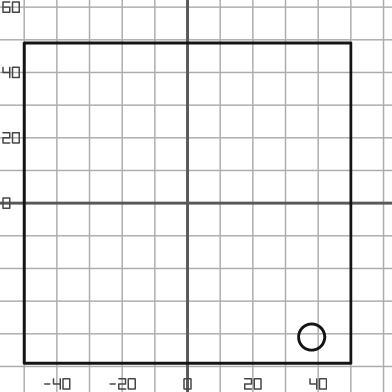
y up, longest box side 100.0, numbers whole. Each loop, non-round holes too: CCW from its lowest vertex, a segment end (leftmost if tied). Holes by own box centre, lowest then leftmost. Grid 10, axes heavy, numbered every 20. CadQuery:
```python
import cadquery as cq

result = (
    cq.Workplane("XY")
    .moveTo(-50.0, -49.0)
    .lineTo(50.0, -49.0)
    .lineTo(50.0, 49.0)
    .lineTo(-50.0, 49.0)
    .close()
    .moveTo(38.0, -41.0)
    .circle(4.0)
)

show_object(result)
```